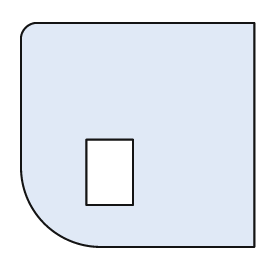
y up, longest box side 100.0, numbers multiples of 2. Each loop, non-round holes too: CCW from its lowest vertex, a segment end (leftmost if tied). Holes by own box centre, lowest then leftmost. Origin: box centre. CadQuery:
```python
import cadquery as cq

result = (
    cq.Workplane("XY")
    .moveTo(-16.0, -48.0)
    .lineTo(50.0, -48.0)
    .lineTo(50.0, 48.0)
    .lineTo(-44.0, 48.0)
    .threePointArc((-48.0, 46.0), (-50.0, 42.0))
    .lineTo(-50.0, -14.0)
    .threePointArc((-40.0, -38.0), (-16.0, -48.0))
    .close()
    .moveTo(-22.0, -30.0)
    .lineTo(-2.0, -30.0)
    .lineTo(-2.0, -2.0)
    .lineTo(-22.0, -2.0)
    .close()
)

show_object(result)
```